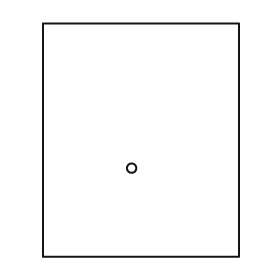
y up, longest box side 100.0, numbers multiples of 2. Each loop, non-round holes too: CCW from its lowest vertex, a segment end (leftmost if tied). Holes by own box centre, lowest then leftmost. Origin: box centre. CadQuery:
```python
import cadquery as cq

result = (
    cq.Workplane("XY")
    .moveTo(-42.0, -50.0)
    .lineTo(42.0, -50.0)
    .lineTo(42.0, 50.0)
    .lineTo(-42.0, 50.0)
    .close()
    .moveTo(-4.0, -12.0)
    .circle(2.0)
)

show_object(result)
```